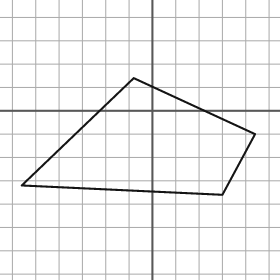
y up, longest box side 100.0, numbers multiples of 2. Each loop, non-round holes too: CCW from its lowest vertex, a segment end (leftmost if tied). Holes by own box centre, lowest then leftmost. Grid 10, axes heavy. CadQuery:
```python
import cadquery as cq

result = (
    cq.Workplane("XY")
    .moveTo(30.0, -36.0)
    .lineTo(44.0, -10.0)
    .lineTo(-8.0, 14.0)
    .lineTo(-56.0, -32.0)
    .close()
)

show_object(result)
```